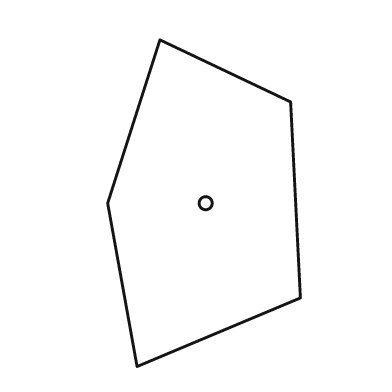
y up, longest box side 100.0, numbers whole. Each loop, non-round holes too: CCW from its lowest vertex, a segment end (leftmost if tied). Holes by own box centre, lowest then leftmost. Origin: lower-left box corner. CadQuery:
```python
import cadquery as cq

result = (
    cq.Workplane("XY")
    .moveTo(9.0, 0.0)
    .lineTo(59.0, 21.0)
    .lineTo(56.0, 81.0)
    .lineTo(16.0, 100.0)
    .lineTo(0.0, 50.0)
    .close()
    .moveTo(30.0, 50.0)
    .circle(2.0)
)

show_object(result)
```